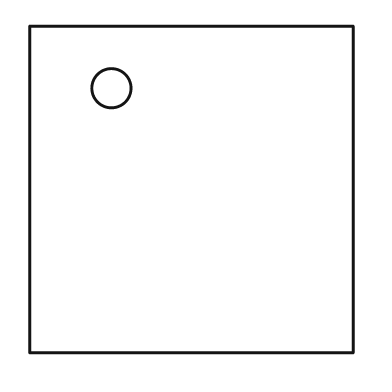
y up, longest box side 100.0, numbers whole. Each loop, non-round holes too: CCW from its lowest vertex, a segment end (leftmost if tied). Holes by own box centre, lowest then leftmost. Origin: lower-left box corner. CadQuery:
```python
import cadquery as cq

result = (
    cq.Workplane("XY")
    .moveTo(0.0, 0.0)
    .lineTo(99.0, 0.0)
    .lineTo(99.0, 100.0)
    .lineTo(0.0, 100.0)
    .close()
    .moveTo(25.0, 81.0)
    .circle(6.0)
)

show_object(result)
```